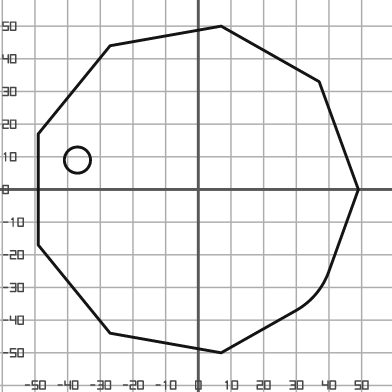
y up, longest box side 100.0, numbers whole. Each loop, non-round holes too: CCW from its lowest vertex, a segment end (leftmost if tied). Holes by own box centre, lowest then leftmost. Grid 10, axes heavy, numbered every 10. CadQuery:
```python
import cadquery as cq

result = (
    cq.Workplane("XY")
    .moveTo(7.0, -50.0)
    .lineTo(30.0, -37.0)
    .threePointArc((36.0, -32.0), (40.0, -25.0))
    .lineTo(49.0, 0.0)
    .lineTo(37.0, 33.0)
    .lineTo(7.0, 50.0)
    .lineTo(-27.0, 44.0)
    .lineTo(-49.0, 17.0)
    .lineTo(-49.0, -17.0)
    .lineTo(-27.0, -44.0)
    .close()
    .moveTo(-37.0, 9.0)
    .circle(4.0)
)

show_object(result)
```